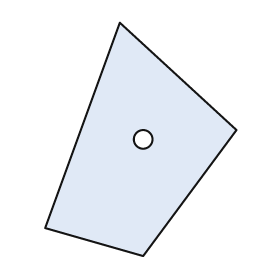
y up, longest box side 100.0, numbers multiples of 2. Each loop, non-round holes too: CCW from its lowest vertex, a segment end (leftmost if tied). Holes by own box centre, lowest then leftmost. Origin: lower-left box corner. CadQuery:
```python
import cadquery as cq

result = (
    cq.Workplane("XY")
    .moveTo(42.0, 0.0)
    .lineTo(82.0, 54.0)
    .lineTo(32.0, 100.0)
    .lineTo(0.0, 12.0)
    .close()
    .moveTo(42.0, 50.0)
    .circle(4.0)
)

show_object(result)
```